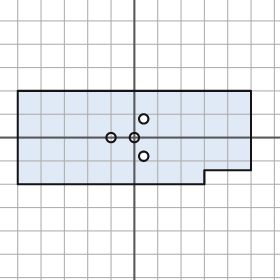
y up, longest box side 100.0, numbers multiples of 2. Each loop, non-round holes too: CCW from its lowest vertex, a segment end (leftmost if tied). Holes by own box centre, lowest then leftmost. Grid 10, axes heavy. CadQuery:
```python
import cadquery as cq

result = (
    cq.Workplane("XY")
    .moveTo(-50.0, -20.0)
    .lineTo(30.0, -20.0)
    .lineTo(30.0, -14.0)
    .lineTo(50.0, -14.0)
    .lineTo(50.0, 20.0)
    .lineTo(-50.0, 20.0)
    .close()
    .moveTo(4.0, -8.0)
    .circle(2.0)
    .moveTo(-10.0, 0.0)
    .circle(2.0)
    .moveTo(0.0, 0.0)
    .circle(2.0)
    .moveTo(4.0, 8.0)
    .circle(2.0)
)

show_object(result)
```